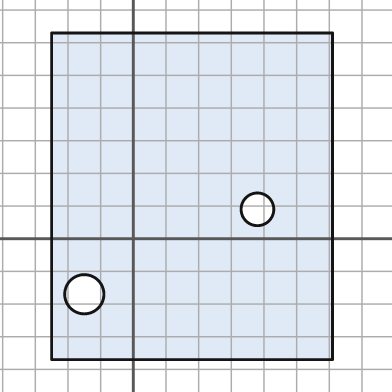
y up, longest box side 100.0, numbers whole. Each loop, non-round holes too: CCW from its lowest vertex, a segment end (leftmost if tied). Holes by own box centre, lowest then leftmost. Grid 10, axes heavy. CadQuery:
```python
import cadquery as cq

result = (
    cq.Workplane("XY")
    .moveTo(-25.0, -37.0)
    .lineTo(61.0, -37.0)
    .lineTo(61.0, 63.0)
    .lineTo(-25.0, 63.0)
    .close()
    .moveTo(-15.0, -17.0)
    .circle(6.0)
    .moveTo(38.0, 9.0)
    .circle(5.0)
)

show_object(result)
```